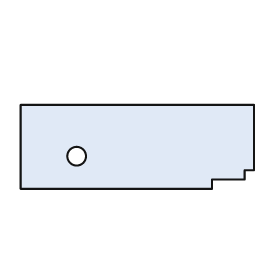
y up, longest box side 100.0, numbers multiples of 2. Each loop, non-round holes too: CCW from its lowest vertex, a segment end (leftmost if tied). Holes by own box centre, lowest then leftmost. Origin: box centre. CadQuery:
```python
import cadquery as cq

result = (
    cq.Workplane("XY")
    .moveTo(-50.0, -18.0)
    .lineTo(32.0, -18.0)
    .lineTo(32.0, -14.0)
    .lineTo(46.0, -14.0)
    .lineTo(46.0, -10.0)
    .lineTo(50.0, -10.0)
    .lineTo(50.0, 18.0)
    .lineTo(-50.0, 18.0)
    .close()
    .moveTo(-26.0, -4.0)
    .circle(4.0)
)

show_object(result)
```